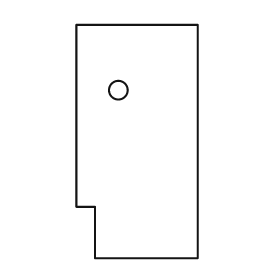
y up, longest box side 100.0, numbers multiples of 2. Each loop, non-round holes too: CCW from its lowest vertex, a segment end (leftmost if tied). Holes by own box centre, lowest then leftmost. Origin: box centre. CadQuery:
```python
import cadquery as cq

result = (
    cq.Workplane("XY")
    .moveTo(-18.0, -50.0)
    .lineTo(26.0, -50.0)
    .lineTo(26.0, 50.0)
    .lineTo(-26.0, 50.0)
    .lineTo(-26.0, -28.0)
    .lineTo(-18.0, -28.0)
    .close()
    .moveTo(-8.0, 22.0)
    .circle(4.0)
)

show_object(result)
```